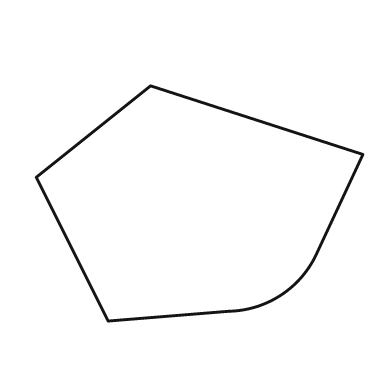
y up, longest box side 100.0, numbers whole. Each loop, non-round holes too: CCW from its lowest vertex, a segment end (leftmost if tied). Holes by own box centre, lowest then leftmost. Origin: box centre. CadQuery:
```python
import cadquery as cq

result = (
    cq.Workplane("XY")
    .moveTo(-28.0, -36.0)
    .lineTo(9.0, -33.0)
    .threePointArc((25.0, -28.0), (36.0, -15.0))
    .lineTo(50.0, 15.0)
    .lineTo(-15.0, 36.0)
    .lineTo(-50.0, 8.0)
    .close()
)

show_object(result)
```